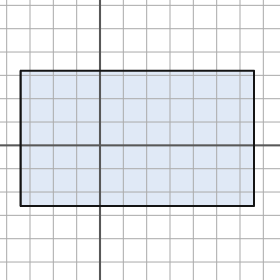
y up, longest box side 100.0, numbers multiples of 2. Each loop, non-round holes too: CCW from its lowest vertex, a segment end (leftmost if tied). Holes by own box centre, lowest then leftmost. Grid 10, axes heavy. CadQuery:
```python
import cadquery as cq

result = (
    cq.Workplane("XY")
    .moveTo(-34.0, -26.0)
    .lineTo(66.0, -26.0)
    .lineTo(66.0, 32.0)
    .lineTo(-34.0, 32.0)
    .close()
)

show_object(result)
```